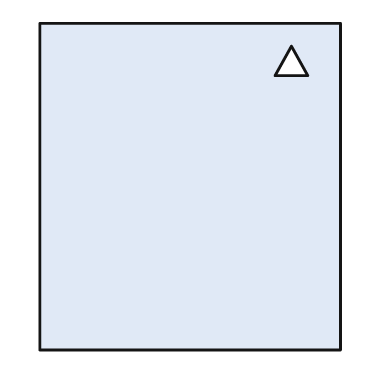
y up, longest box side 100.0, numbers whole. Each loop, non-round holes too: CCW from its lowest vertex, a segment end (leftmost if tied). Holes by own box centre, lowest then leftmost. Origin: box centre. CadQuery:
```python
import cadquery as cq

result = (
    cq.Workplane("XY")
    .moveTo(-46.0, -50.0)
    .lineTo(46.0, -50.0)
    .lineTo(46.0, 50.0)
    .lineTo(-46.0, 50.0)
    .close()
    .moveTo(26.0, 34.0)
    .lineTo(36.0, 34.0)
    .lineTo(31.0, 43.0)
    .close()
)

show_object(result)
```